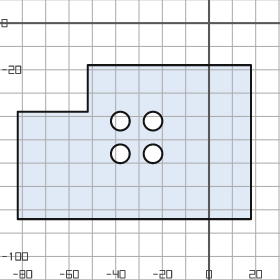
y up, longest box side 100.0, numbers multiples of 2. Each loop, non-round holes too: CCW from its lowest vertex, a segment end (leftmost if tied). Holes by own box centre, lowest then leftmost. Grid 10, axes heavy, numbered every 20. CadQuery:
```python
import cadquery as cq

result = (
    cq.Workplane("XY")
    .moveTo(-82.0, -84.0)
    .lineTo(18.0, -84.0)
    .lineTo(18.0, -18.0)
    .lineTo(-52.0, -18.0)
    .lineTo(-52.0, -38.0)
    .lineTo(-82.0, -38.0)
    .close()
    .moveTo(-38.0, -56.0)
    .circle(4.0)
    .moveTo(-24.0, -56.0)
    .circle(4.0)
    .moveTo(-38.0, -42.0)
    .circle(4.0)
    .moveTo(-24.0, -42.0)
    .circle(4.0)
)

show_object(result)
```